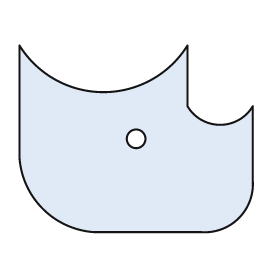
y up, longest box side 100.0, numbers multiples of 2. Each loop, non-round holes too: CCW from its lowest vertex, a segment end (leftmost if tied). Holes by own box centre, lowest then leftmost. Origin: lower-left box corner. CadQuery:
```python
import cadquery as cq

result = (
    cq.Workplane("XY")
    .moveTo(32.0, 0.0)
    .lineTo(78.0, 0.0)
    .threePointArc((94.0, 6.0), (100.0, 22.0))
    .lineTo(100.0, 54.0)
    .threePointArc((86.0, 46.0), (72.0, 54.0))
    .lineTo(72.0, 80.0)
    .threePointArc((36.0, 60.0), (0.0, 80.0))
    .lineTo(0.0, 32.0)
    .threePointArc((10.0, 10.0), (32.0, 0.0))
    .close()
    .moveTo(50.0, 40.0)
    .circle(4.0)
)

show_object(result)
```